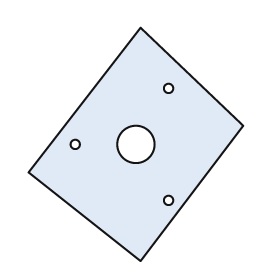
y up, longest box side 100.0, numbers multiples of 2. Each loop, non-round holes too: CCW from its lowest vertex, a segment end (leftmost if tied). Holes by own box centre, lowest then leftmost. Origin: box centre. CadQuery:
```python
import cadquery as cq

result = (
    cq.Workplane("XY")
    .moveTo(2.0, -50.0)
    .lineTo(46.0, 8.0)
    .lineTo(2.0, 50.0)
    .lineTo(-46.0, -12.0)
    .close()
    .moveTo(14.0, -24.0)
    .circle(2.0)
    .moveTo(-26.0, 0.0)
    .circle(2.0)
    .moveTo(0.0, 0.0)
    .circle(8.0)
    .moveTo(14.0, 24.0)
    .circle(2.0)
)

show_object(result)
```